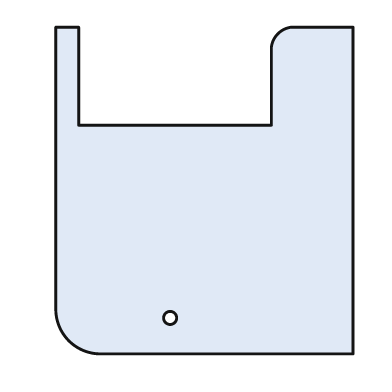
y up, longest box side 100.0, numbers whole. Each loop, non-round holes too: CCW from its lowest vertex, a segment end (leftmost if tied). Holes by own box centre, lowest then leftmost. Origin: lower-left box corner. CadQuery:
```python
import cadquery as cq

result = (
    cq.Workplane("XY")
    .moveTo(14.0, 0.0)
    .lineTo(91.0, 0.0)
    .lineTo(91.0, 100.0)
    .lineTo(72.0, 100.0)
    .threePointArc((68.0, 98.0), (66.0, 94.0))
    .lineTo(66.0, 70.0)
    .lineTo(7.0, 70.0)
    .lineTo(7.0, 100.0)
    .lineTo(0.0, 100.0)
    .lineTo(0.0, 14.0)
    .threePointArc((4.0, 4.0), (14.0, 0.0))
    .close()
    .moveTo(35.0, 11.0)
    .circle(2.0)
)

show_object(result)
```